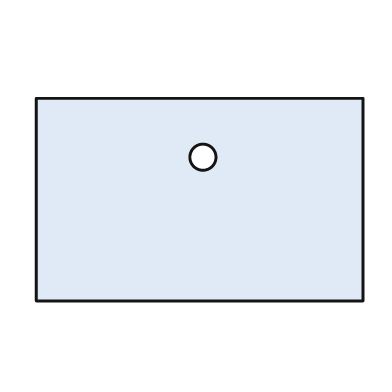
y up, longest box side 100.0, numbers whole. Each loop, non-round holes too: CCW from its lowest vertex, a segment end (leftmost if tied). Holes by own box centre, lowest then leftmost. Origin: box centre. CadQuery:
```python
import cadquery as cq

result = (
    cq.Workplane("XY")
    .moveTo(-50.0, -31.0)
    .lineTo(50.0, -31.0)
    .lineTo(50.0, 31.0)
    .lineTo(-50.0, 31.0)
    .close()
    .moveTo(1.0, 13.0)
    .circle(4.0)
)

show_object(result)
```